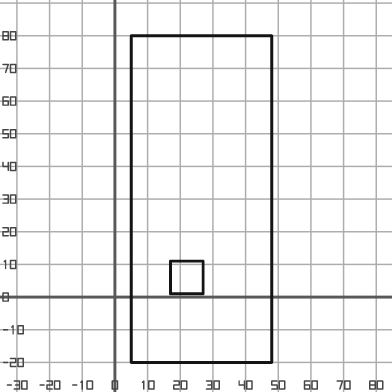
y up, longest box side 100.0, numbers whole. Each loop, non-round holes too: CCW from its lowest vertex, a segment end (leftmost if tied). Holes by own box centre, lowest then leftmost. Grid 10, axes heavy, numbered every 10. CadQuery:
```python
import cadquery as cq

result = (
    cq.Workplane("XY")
    .moveTo(5.0, -20.0)
    .lineTo(48.0, -20.0)
    .lineTo(48.0, 80.0)
    .lineTo(5.0, 80.0)
    .close()
    .moveTo(17.0, 1.0)
    .lineTo(27.0, 1.0)
    .lineTo(27.0, 11.0)
    .lineTo(17.0, 11.0)
    .close()
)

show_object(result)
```